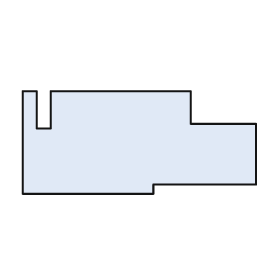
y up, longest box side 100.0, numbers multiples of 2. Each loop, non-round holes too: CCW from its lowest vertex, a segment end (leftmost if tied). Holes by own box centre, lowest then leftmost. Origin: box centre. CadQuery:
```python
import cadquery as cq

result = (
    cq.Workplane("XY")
    .moveTo(-50.0, -22.0)
    .lineTo(6.0, -22.0)
    .lineTo(6.0, -18.0)
    .lineTo(50.0, -18.0)
    .lineTo(50.0, 8.0)
    .lineTo(22.0, 8.0)
    .lineTo(22.0, 22.0)
    .lineTo(-38.0, 22.0)
    .lineTo(-38.0, 6.0)
    .lineTo(-44.0, 6.0)
    .lineTo(-44.0, 22.0)
    .lineTo(-50.0, 22.0)
    .close()
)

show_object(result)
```